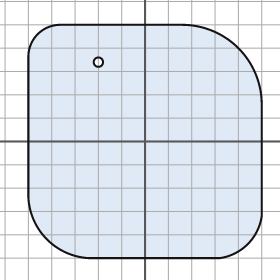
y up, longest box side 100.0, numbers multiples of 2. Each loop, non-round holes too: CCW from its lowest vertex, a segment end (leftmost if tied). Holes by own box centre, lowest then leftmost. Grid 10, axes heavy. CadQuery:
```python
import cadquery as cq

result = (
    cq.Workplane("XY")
    .moveTo(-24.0, -50.0)
    .lineTo(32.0, -50.0)
    .threePointArc((44.0, -44.0), (50.0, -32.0))
    .lineTo(50.0, 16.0)
    .threePointArc((40.0, 40.0), (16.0, 50.0))
    .lineTo(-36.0, 50.0)
    .threePointArc((-46.0, 46.0), (-50.0, 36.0))
    .lineTo(-50.0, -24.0)
    .threePointArc((-42.0, -42.0), (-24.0, -50.0))
    .close()
    .moveTo(-20.0, 34.0)
    .circle(2.0)
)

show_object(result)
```